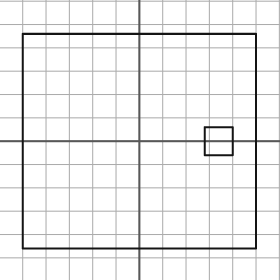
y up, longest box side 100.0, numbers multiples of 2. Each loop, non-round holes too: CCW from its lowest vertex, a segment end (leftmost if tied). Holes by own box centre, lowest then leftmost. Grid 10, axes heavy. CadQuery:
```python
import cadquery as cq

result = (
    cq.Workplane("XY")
    .moveTo(-50.0, -46.0)
    .lineTo(50.0, -46.0)
    .lineTo(50.0, 46.0)
    .lineTo(-50.0, 46.0)
    .close()
    .moveTo(28.0, -6.0)
    .lineTo(40.0, -6.0)
    .lineTo(40.0, 6.0)
    .lineTo(28.0, 6.0)
    .close()
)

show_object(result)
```